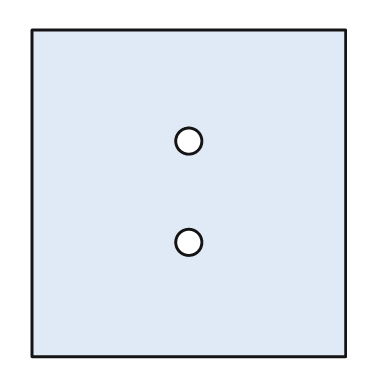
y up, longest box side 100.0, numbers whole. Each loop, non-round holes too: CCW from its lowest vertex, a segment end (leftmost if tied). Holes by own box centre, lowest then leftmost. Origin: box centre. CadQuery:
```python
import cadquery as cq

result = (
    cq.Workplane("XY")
    .moveTo(-48.0, -50.0)
    .lineTo(48.0, -50.0)
    .lineTo(48.0, 50.0)
    .lineTo(-48.0, 50.0)
    .close()
    .moveTo(0.0, -15.0)
    .circle(4.0)
    .moveTo(0.0, 16.0)
    .circle(4.0)
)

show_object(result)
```